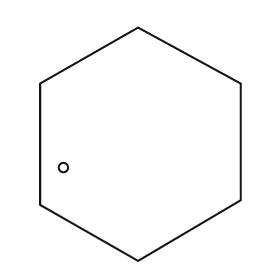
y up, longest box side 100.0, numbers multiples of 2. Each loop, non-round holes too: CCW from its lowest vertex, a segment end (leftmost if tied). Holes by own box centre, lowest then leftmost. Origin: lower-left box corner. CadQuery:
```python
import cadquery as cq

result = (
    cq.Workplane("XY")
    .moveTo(42.0, 0.0)
    .lineTo(86.0, 26.0)
    .lineTo(86.0, 76.0)
    .lineTo(42.0, 100.0)
    .lineTo(0.0, 76.0)
    .lineTo(0.0, 24.0)
    .close()
    .moveTo(10.0, 40.0)
    .circle(2.0)
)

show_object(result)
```